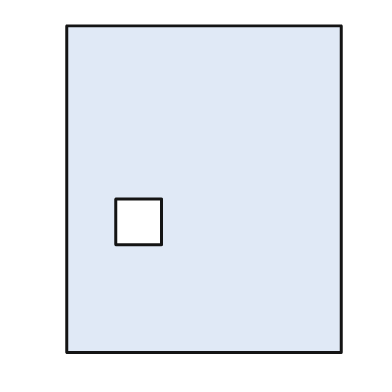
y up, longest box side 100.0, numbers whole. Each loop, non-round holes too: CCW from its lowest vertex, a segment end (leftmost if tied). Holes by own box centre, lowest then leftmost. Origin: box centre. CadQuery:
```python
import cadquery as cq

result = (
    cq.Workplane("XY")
    .moveTo(-42.0, -50.0)
    .lineTo(42.0, -50.0)
    .lineTo(42.0, 50.0)
    .lineTo(-42.0, 50.0)
    .close()
    .moveTo(-27.0, -17.0)
    .lineTo(-13.0, -17.0)
    .lineTo(-13.0, -3.0)
    .lineTo(-27.0, -3.0)
    .close()
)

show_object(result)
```